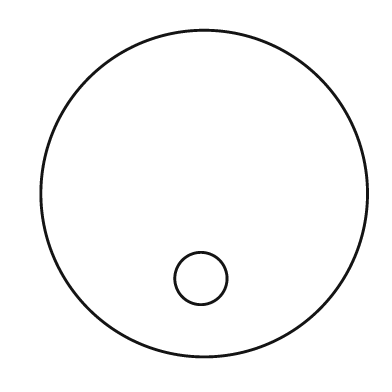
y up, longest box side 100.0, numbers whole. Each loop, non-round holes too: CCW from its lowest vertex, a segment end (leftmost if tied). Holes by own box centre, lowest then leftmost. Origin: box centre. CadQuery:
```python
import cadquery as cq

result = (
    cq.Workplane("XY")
    .moveTo(0.0, 0.0)
    .circle(50.0)
    .moveTo(-1.0, -26.0)
    .circle(8.0)
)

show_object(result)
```